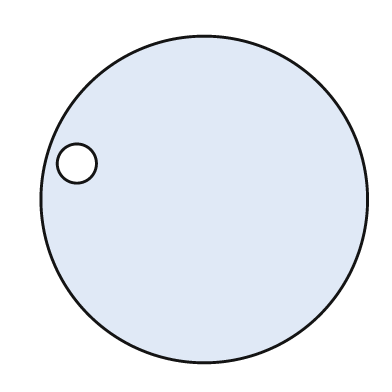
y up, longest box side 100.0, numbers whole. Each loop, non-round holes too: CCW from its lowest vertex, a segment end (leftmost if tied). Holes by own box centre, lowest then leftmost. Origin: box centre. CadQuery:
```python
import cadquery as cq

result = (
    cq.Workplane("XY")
    .moveTo(0.0, 0.0)
    .circle(50.0)
    .moveTo(-39.0, 11.0)
    .circle(6.0)
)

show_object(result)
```